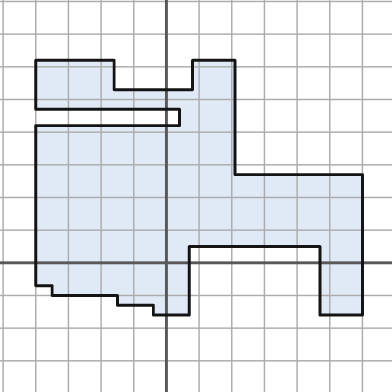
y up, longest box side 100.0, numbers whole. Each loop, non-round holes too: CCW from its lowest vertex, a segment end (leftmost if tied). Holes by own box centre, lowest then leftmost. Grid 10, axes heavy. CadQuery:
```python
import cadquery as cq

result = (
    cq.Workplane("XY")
    .moveTo(-4.0, -16.0)
    .lineTo(7.0, -16.0)
    .lineTo(7.0, 5.0)
    .lineTo(47.0, 5.0)
    .lineTo(47.0, -16.0)
    .lineTo(60.0, -16.0)
    .lineTo(60.0, 27.0)
    .lineTo(21.0, 27.0)
    .lineTo(21.0, 62.0)
    .lineTo(8.0, 62.0)
    .lineTo(8.0, 53.0)
    .lineTo(-16.0, 53.0)
    .lineTo(-16.0, 62.0)
    .lineTo(-40.0, 62.0)
    .lineTo(-40.0, 47.0)
    .lineTo(4.0, 47.0)
    .lineTo(4.0, 42.0)
    .lineTo(-40.0, 42.0)
    .lineTo(-40.0, -7.0)
    .lineTo(-35.0, -7.0)
    .lineTo(-35.0, -10.0)
    .lineTo(-15.0, -10.0)
    .lineTo(-15.0, -13.0)
    .lineTo(-4.0, -13.0)
    .close()
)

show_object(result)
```